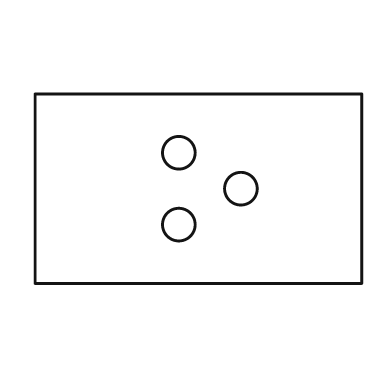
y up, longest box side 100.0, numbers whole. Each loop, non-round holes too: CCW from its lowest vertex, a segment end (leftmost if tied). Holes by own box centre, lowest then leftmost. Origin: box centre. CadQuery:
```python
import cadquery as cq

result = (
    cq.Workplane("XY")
    .moveTo(-50.0, -29.0)
    .lineTo(50.0, -29.0)
    .lineTo(50.0, 29.0)
    .lineTo(-50.0, 29.0)
    .close()
    .moveTo(-6.0, -11.0)
    .circle(5.0)
    .moveTo(13.0, 0.0)
    .circle(5.0)
    .moveTo(-6.0, 11.0)
    .circle(5.0)
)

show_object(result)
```